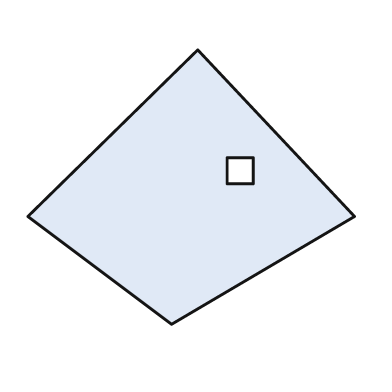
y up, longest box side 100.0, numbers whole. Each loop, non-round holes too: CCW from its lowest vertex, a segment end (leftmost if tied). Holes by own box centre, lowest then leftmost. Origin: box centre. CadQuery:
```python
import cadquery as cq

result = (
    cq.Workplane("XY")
    .moveTo(-6.0, -42.0)
    .lineTo(50.0, -9.0)
    .lineTo(2.0, 42.0)
    .lineTo(-50.0, -9.0)
    .close()
    .moveTo(11.0, 1.0)
    .lineTo(19.0, 1.0)
    .lineTo(19.0, 9.0)
    .lineTo(11.0, 9.0)
    .close()
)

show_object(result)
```